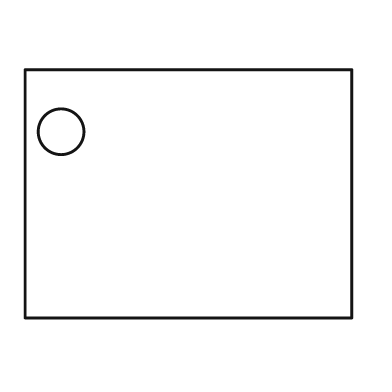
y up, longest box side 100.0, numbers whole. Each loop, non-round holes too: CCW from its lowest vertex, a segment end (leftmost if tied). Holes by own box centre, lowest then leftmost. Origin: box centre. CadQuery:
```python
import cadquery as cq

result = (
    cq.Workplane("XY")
    .moveTo(-50.0, -38.0)
    .lineTo(50.0, -38.0)
    .lineTo(50.0, 38.0)
    .lineTo(-50.0, 38.0)
    .close()
    .moveTo(-39.0, 19.0)
    .circle(7.0)
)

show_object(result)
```